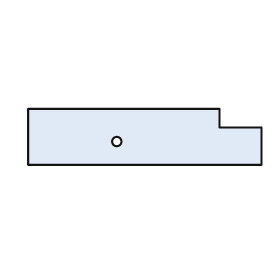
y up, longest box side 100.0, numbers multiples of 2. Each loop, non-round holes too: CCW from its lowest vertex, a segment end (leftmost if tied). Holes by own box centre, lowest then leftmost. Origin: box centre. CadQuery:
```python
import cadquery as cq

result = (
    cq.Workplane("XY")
    .moveTo(-50.0, -12.0)
    .lineTo(50.0, -12.0)
    .lineTo(50.0, 4.0)
    .lineTo(32.0, 4.0)
    .lineTo(32.0, 12.0)
    .lineTo(-50.0, 12.0)
    .close()
    .moveTo(-12.0, -2.0)
    .circle(2.0)
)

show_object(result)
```